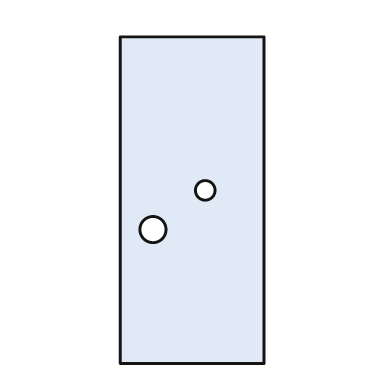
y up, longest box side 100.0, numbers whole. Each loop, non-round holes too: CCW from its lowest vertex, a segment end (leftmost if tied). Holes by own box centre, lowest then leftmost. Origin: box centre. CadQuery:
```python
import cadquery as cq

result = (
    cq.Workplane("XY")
    .moveTo(-22.0, -50.0)
    .lineTo(22.0, -50.0)
    .lineTo(22.0, 50.0)
    .lineTo(-22.0, 50.0)
    .close()
    .moveTo(-12.0, -9.0)
    .circle(4.0)
    .moveTo(4.0, 3.0)
    .circle(3.0)
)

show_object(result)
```